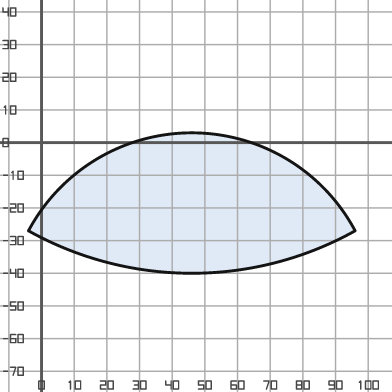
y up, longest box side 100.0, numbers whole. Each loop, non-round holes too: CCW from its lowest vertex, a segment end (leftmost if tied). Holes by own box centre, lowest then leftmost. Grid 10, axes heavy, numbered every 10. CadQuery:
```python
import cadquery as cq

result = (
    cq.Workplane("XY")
    .moveTo(-4.0, -27.0)
    .threePointArc((46.0, -40.0), (96.0, -27.0))
    .threePointArc((46.0, 3.0), (-4.0, -27.0))
    .close()
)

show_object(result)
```